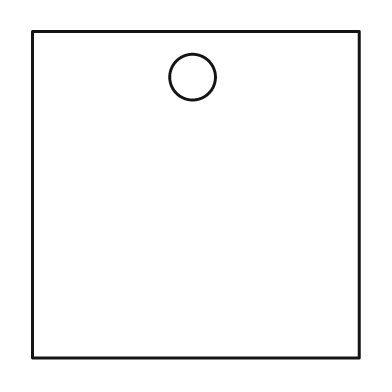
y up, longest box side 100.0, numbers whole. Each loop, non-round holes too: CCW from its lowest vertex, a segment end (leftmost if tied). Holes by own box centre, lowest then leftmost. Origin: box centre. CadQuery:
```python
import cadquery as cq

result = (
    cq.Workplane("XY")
    .moveTo(-50.0, -50.0)
    .lineTo(50.0, -50.0)
    .lineTo(50.0, 50.0)
    .lineTo(-50.0, 50.0)
    .close()
    .moveTo(-1.0, 36.0)
    .circle(7.0)
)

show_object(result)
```